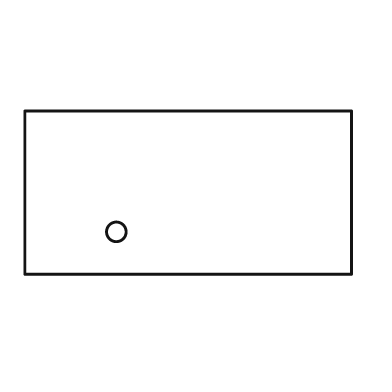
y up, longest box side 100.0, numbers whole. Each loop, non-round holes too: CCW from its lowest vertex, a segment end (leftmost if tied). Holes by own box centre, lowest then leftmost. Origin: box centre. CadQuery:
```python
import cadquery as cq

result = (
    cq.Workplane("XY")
    .moveTo(-50.0, -25.0)
    .lineTo(50.0, -25.0)
    .lineTo(50.0, 25.0)
    .lineTo(-50.0, 25.0)
    .close()
    .moveTo(-22.0, -12.0)
    .circle(3.0)
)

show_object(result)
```